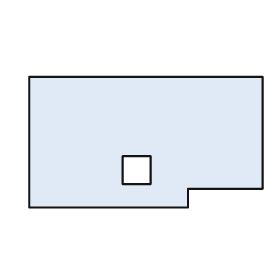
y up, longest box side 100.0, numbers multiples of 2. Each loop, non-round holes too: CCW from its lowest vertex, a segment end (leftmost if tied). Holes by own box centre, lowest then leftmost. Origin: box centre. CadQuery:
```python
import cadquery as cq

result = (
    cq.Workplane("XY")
    .moveTo(-50.0, -28.0)
    .lineTo(18.0, -28.0)
    .lineTo(18.0, -20.0)
    .lineTo(50.0, -20.0)
    .lineTo(50.0, 28.0)
    .lineTo(-50.0, 28.0)
    .close()
    .moveTo(-10.0, -18.0)
    .lineTo(2.0, -18.0)
    .lineTo(2.0, -6.0)
    .lineTo(-10.0, -6.0)
    .close()
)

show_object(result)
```